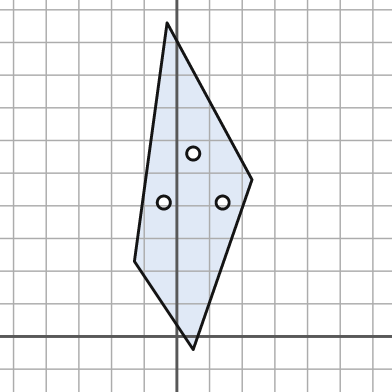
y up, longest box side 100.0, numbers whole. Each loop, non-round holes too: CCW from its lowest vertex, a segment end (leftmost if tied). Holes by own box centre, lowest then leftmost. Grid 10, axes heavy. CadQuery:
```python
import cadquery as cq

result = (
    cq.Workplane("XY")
    .moveTo(5.0, -4.0)
    .lineTo(23.0, 48.0)
    .lineTo(-3.0, 96.0)
    .lineTo(-13.0, 23.0)
    .close()
    .moveTo(-4.0, 41.0)
    .circle(2.0)
    .moveTo(14.0, 41.0)
    .circle(2.0)
    .moveTo(5.0, 56.0)
    .circle(2.0)
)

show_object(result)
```